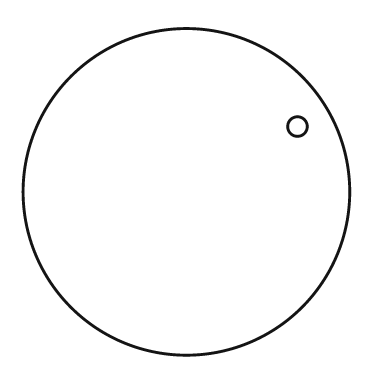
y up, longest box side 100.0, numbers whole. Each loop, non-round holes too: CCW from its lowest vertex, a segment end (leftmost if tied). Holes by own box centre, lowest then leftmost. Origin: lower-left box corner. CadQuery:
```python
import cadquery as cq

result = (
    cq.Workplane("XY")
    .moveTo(50.0, 50.0)
    .circle(50.0)
    .moveTo(84.0, 70.0)
    .circle(3.0)
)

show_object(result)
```